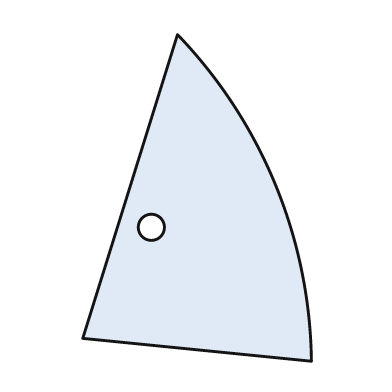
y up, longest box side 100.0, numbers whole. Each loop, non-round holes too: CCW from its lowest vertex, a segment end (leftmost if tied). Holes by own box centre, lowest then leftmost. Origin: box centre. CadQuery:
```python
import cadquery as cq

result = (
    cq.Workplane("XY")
    .moveTo(35.0, -50.0)
    .threePointArc((24.0, 4.0), (-6.0, 50.0))
    .lineTo(-35.0, -43.0)
    .close()
    .moveTo(-14.0, -9.0)
    .circle(4.0)
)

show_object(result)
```